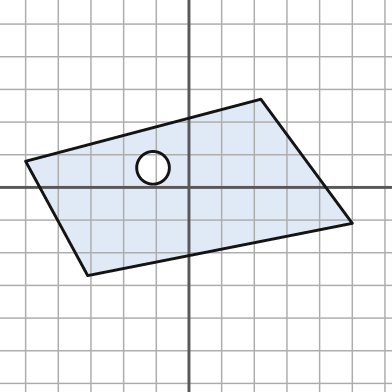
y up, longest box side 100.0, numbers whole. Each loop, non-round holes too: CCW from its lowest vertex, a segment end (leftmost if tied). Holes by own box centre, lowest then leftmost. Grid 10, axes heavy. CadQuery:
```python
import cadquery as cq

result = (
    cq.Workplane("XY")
    .moveTo(-31.0, -27.0)
    .lineTo(50.0, -11.0)
    .lineTo(22.0, 27.0)
    .lineTo(-50.0, 8.0)
    .close()
    .moveTo(-11.0, 6.0)
    .circle(5.0)
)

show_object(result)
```